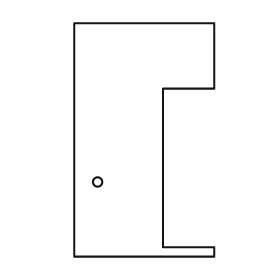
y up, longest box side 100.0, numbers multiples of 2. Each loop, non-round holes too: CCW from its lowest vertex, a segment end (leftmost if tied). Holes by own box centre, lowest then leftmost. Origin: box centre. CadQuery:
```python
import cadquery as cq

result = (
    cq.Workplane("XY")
    .moveTo(-30.0, -50.0)
    .lineTo(30.0, -50.0)
    .lineTo(30.0, -46.0)
    .lineTo(8.0, -46.0)
    .lineTo(8.0, 22.0)
    .lineTo(30.0, 22.0)
    .lineTo(30.0, 50.0)
    .lineTo(-30.0, 50.0)
    .close()
    .moveTo(-20.0, -18.0)
    .circle(2.0)
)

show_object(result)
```